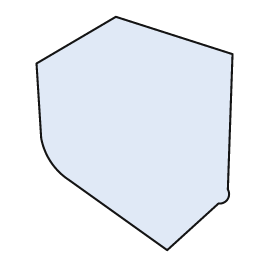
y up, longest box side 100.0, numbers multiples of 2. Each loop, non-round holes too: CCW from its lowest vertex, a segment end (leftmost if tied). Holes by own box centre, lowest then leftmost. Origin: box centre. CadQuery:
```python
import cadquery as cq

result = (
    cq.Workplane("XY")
    .moveTo(14.0, -50.0)
    .lineTo(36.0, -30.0)
    .threePointArc((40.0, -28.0), (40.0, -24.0))
    .lineTo(42.0, 34.0)
    .lineTo(-8.0, 50.0)
    .lineTo(-42.0, 30.0)
    .lineTo(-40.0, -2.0)
    .threePointArc((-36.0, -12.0), (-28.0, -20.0))
    .close()
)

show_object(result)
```